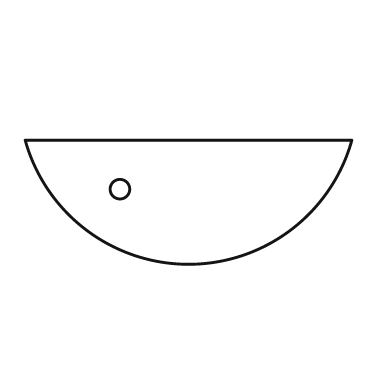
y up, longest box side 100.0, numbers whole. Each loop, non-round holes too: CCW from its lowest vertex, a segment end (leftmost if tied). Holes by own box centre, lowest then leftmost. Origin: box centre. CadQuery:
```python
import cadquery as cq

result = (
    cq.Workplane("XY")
    .moveTo(-50.0, 19.0)
    .threePointArc((0.0, -19.0), (50.0, 19.0))
    .close()
    .moveTo(-21.0, 4.0)
    .circle(3.0)
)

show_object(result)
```